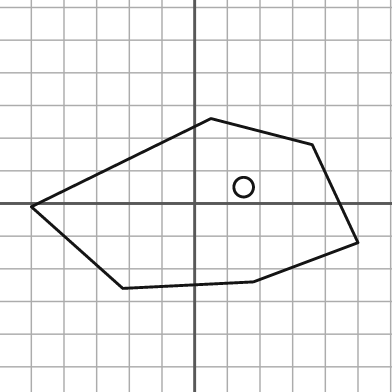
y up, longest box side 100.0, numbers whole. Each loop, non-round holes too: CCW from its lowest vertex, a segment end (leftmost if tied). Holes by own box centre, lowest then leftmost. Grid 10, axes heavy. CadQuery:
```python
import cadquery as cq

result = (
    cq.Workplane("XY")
    .moveTo(-22.0, -26.0)
    .lineTo(18.0, -24.0)
    .lineTo(50.0, -12.0)
    .lineTo(36.0, 18.0)
    .lineTo(5.0, 26.0)
    .lineTo(-50.0, -1.0)
    .close()
    .moveTo(15.0, 5.0)
    .circle(3.0)
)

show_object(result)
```